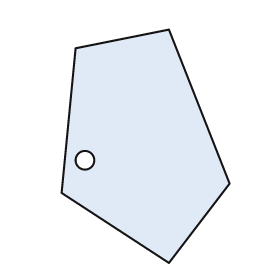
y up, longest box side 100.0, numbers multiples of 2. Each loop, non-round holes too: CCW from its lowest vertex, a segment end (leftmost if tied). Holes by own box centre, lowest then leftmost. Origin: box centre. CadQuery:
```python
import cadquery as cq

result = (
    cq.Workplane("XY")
    .moveTo(10.0, -50.0)
    .lineTo(36.0, -16.0)
    .lineTo(10.0, 50.0)
    .lineTo(-30.0, 42.0)
    .lineTo(-36.0, -20.0)
    .close()
    .moveTo(-26.0, -6.0)
    .circle(4.0)
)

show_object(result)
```